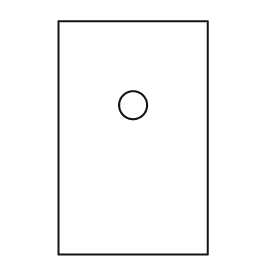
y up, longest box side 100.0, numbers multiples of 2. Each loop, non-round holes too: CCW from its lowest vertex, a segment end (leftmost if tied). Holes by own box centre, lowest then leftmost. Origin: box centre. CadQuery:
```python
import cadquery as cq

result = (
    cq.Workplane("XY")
    .moveTo(-32.0, -50.0)
    .lineTo(32.0, -50.0)
    .lineTo(32.0, 50.0)
    .lineTo(-32.0, 50.0)
    .close()
    .moveTo(0.0, 14.0)
    .circle(6.0)
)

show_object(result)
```